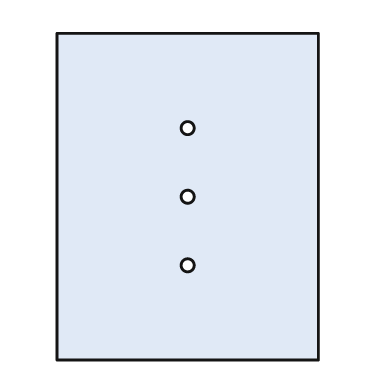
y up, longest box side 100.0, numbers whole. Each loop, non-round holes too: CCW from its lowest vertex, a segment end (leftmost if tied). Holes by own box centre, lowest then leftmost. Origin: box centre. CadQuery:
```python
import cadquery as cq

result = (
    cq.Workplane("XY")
    .moveTo(-40.0, -50.0)
    .lineTo(40.0, -50.0)
    .lineTo(40.0, 50.0)
    .lineTo(-40.0, 50.0)
    .close()
    .moveTo(0.0, -21.0)
    .circle(2.0)
    .moveTo(0.0, 0.0)
    .circle(2.0)
    .moveTo(0.0, 21.0)
    .circle(2.0)
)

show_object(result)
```